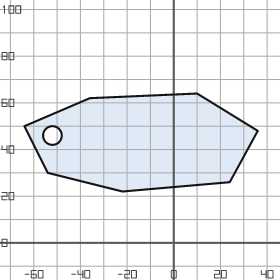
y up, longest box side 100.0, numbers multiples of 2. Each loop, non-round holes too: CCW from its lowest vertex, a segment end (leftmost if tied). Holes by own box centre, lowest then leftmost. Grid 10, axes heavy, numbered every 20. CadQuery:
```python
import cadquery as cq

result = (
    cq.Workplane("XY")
    .moveTo(-22.0, 22.0)
    .lineTo(24.0, 26.0)
    .lineTo(36.0, 48.0)
    .lineTo(10.0, 64.0)
    .lineTo(-36.0, 62.0)
    .lineTo(-64.0, 50.0)
    .lineTo(-54.0, 30.0)
    .close()
    .moveTo(-52.0, 46.0)
    .circle(4.0)
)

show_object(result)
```